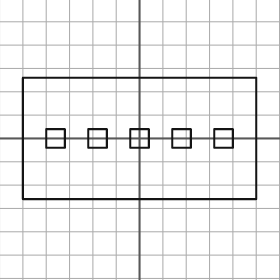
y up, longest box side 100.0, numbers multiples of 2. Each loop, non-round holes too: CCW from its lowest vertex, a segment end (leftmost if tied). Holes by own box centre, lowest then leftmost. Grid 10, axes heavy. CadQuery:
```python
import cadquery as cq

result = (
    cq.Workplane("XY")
    .moveTo(-50.0, -26.0)
    .lineTo(50.0, -26.0)
    .lineTo(50.0, 26.0)
    .lineTo(-50.0, 26.0)
    .close()
    .moveTo(-40.0, -4.0)
    .lineTo(-32.0, -4.0)
    .lineTo(-32.0, 4.0)
    .lineTo(-40.0, 4.0)
    .close()
    .moveTo(-22.0, -4.0)
    .lineTo(-14.0, -4.0)
    .lineTo(-14.0, 4.0)
    .lineTo(-22.0, 4.0)
    .close()
    .moveTo(-4.0, -4.0)
    .lineTo(4.0, -4.0)
    .lineTo(4.0, 4.0)
    .lineTo(-4.0, 4.0)
    .close()
    .moveTo(14.0, -4.0)
    .lineTo(22.0, -4.0)
    .lineTo(22.0, 4.0)
    .lineTo(14.0, 4.0)
    .close()
    .moveTo(32.0, -4.0)
    .lineTo(40.0, -4.0)
    .lineTo(40.0, 4.0)
    .lineTo(32.0, 4.0)
    .close()
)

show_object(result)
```